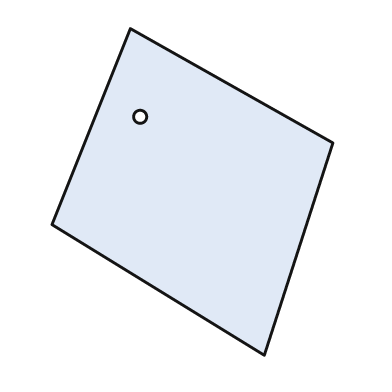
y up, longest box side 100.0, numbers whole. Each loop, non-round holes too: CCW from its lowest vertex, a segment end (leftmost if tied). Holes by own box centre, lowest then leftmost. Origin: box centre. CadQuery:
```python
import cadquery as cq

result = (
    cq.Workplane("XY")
    .moveTo(22.0, -50.0)
    .lineTo(43.0, 15.0)
    .lineTo(-19.0, 50.0)
    .lineTo(-43.0, -10.0)
    .close()
    .moveTo(-16.0, 23.0)
    .circle(2.0)
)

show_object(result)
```